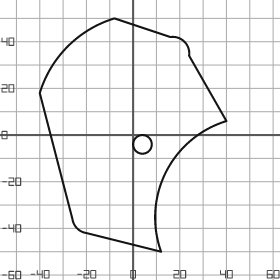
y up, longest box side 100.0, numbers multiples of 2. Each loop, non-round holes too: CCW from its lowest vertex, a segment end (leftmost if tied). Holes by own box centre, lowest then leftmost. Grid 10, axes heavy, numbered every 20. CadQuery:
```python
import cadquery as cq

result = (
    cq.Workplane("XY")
    .moveTo(12.0, -50.0)
    .threePointArc((14.0, -16.0), (40.0, 6.0))
    .lineTo(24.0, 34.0)
    .threePointArc((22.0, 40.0), (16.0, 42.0))
    .lineTo(-8.0, 50.0)
    .threePointArc((-28.0, 38.0), (-40.0, 18.0))
    .lineTo(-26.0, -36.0)
    .threePointArc((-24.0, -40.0), (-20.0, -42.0))
    .close()
    .moveTo(4.0, -4.0)
    .circle(4.0)
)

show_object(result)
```